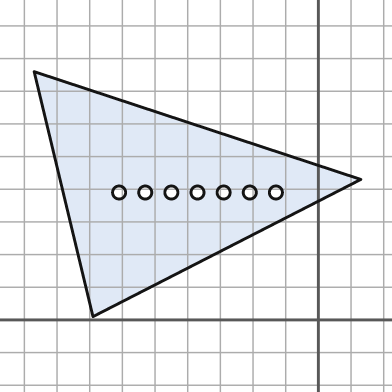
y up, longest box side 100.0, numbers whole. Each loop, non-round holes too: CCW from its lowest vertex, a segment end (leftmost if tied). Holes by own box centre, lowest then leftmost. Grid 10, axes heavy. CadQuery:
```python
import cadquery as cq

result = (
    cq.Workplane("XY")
    .moveTo(-69.0, 1.0)
    .lineTo(13.0, 43.0)
    .lineTo(-87.0, 76.0)
    .close()
    .moveTo(-61.0, 39.0)
    .circle(2.0)
    .moveTo(-53.0, 39.0)
    .circle(2.0)
    .moveTo(-45.0, 39.0)
    .circle(2.0)
    .moveTo(-37.0, 39.0)
    .circle(2.0)
    .moveTo(-29.0, 39.0)
    .circle(2.0)
    .moveTo(-21.0, 39.0)
    .circle(2.0)
    .moveTo(-13.0, 39.0)
    .circle(2.0)
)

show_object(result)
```